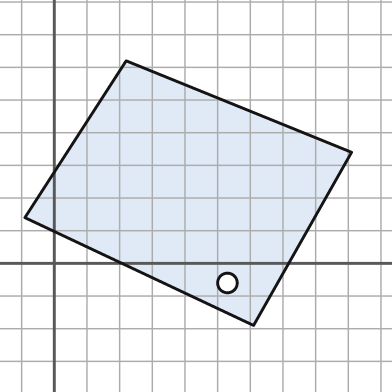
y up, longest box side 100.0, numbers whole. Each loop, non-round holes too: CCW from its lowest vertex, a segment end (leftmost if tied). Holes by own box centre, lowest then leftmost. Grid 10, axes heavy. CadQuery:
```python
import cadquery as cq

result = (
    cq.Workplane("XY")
    .moveTo(61.0, -19.0)
    .lineTo(91.0, 34.0)
    .lineTo(22.0, 62.0)
    .lineTo(-9.0, 14.0)
    .close()
    .moveTo(53.0, -6.0)
    .circle(3.0)
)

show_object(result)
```